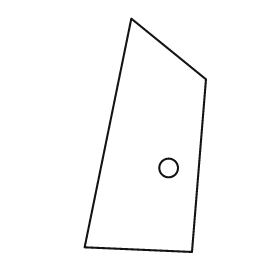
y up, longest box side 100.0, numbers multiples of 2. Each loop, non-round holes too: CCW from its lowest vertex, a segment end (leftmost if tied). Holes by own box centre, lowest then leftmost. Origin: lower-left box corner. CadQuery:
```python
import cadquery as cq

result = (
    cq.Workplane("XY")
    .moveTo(46.0, 0.0)
    .lineTo(52.0, 74.0)
    .lineTo(20.0, 100.0)
    .lineTo(0.0, 2.0)
    .close()
    .moveTo(36.0, 36.0)
    .circle(4.0)
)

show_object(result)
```